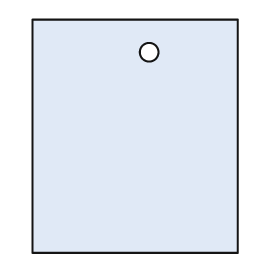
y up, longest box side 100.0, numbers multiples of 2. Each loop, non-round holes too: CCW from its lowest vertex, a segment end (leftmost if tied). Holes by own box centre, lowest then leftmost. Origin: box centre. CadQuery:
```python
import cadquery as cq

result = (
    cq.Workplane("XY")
    .moveTo(-44.0, -50.0)
    .lineTo(44.0, -50.0)
    .lineTo(44.0, 50.0)
    .lineTo(-44.0, 50.0)
    .close()
    .moveTo(6.0, 36.0)
    .circle(4.0)
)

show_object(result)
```